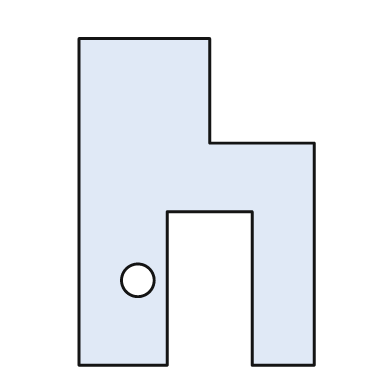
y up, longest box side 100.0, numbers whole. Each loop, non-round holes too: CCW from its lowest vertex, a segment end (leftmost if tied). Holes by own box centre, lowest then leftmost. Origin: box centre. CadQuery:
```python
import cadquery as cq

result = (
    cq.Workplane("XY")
    .moveTo(-36.0, -50.0)
    .lineTo(-9.0, -50.0)
    .lineTo(-9.0, -3.0)
    .lineTo(17.0, -3.0)
    .lineTo(17.0, -50.0)
    .lineTo(36.0, -50.0)
    .lineTo(36.0, 18.0)
    .lineTo(4.0, 18.0)
    .lineTo(4.0, 50.0)
    .lineTo(-36.0, 50.0)
    .close()
    .moveTo(-18.0, -24.0)
    .circle(5.0)
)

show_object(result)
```